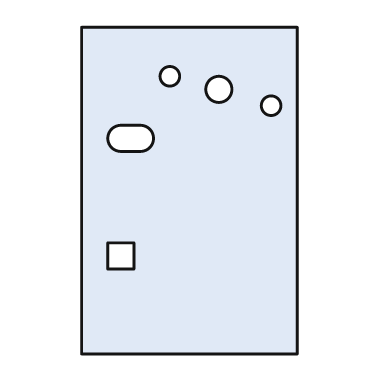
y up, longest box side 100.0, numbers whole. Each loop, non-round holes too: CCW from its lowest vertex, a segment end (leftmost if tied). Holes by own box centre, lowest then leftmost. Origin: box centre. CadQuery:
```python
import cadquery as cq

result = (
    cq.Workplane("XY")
    .moveTo(-33.0, -50.0)
    .lineTo(33.0, -50.0)
    .lineTo(33.0, 50.0)
    .lineTo(-33.0, 50.0)
    .close()
    .moveTo(-25.0, -24.0)
    .lineTo(-17.0, -24.0)
    .lineTo(-17.0, -16.0)
    .lineTo(-25.0, -16.0)
    .close()
    .moveTo(-21.0, 12.0)
    .lineTo(-15.0, 12.0)
    .threePointArc((-11.0, 16.0), (-15.0, 20.0))
    .lineTo(-21.0, 20.0)
    .threePointArc((-25.0, 16.0), (-21.0, 12.0))
    .close()
    .moveTo(25.0, 26.0)
    .circle(3.0)
    .moveTo(9.0, 31.0)
    .circle(4.0)
    .moveTo(-6.0, 35.0)
    .circle(3.0)
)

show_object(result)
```